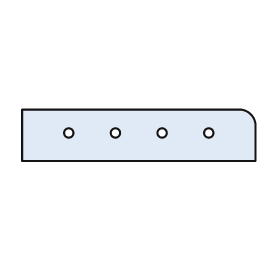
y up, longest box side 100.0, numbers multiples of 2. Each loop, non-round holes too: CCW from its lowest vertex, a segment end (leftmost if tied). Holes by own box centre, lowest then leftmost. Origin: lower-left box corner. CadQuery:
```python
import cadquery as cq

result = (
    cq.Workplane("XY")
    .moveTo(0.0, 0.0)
    .lineTo(100.0, 0.0)
    .lineTo(100.0, 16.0)
    .threePointArc((98.0, 20.0), (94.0, 22.0))
    .lineTo(0.0, 22.0)
    .close()
    .moveTo(20.0, 12.0)
    .circle(2.0)
    .moveTo(40.0, 12.0)
    .circle(2.0)
    .moveTo(60.0, 12.0)
    .circle(2.0)
    .moveTo(80.0, 12.0)
    .circle(2.0)
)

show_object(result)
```